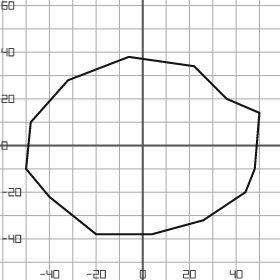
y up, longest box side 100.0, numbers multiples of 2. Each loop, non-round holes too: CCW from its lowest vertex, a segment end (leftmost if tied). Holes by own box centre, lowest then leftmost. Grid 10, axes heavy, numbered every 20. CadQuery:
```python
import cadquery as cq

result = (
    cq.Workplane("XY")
    .moveTo(-20.0, -38.0)
    .lineTo(4.0, -38.0)
    .lineTo(26.0, -32.0)
    .lineTo(44.0, -20.0)
    .lineTo(48.0, -10.0)
    .lineTo(50.0, 14.0)
    .lineTo(36.0, 20.0)
    .lineTo(22.0, 34.0)
    .lineTo(-6.0, 38.0)
    .lineTo(-32.0, 28.0)
    .lineTo(-48.0, 10.0)
    .lineTo(-50.0, -10.0)
    .lineTo(-40.0, -22.0)
    .close()
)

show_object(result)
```